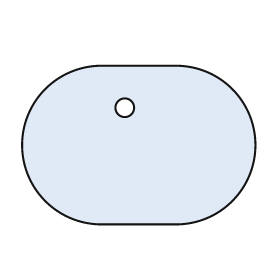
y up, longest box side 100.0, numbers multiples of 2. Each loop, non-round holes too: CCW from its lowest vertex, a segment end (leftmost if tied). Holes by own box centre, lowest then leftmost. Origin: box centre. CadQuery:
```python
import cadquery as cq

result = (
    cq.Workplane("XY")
    .moveTo(-16.0, -34.0)
    .lineTo(16.0, -34.0)
    .threePointArc((50.0, 0.0), (16.0, 34.0))
    .lineTo(-16.0, 34.0)
    .threePointArc((-50.0, 0.0), (-16.0, -34.0))
    .close()
    .moveTo(-6.0, 16.0)
    .circle(4.0)
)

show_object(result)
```